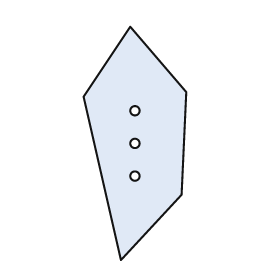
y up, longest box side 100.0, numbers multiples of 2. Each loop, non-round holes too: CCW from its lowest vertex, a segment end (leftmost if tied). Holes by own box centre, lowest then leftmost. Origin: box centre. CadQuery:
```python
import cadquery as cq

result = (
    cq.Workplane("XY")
    .moveTo(-6.0, -50.0)
    .lineTo(20.0, -22.0)
    .lineTo(22.0, 22.0)
    .lineTo(-2.0, 50.0)
    .lineTo(-22.0, 20.0)
    .close()
    .moveTo(0.0, -14.0)
    .circle(2.0)
    .moveTo(0.0, 0.0)
    .circle(2.0)
    .moveTo(0.0, 14.0)
    .circle(2.0)
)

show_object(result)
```